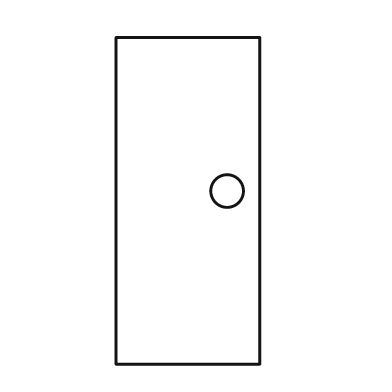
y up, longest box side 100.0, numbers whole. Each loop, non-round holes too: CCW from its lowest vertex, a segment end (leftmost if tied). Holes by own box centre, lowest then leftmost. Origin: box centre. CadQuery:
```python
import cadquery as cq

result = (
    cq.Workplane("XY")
    .moveTo(-22.0, -50.0)
    .lineTo(22.0, -50.0)
    .lineTo(22.0, 50.0)
    .lineTo(-22.0, 50.0)
    .close()
    .moveTo(12.0, 3.0)
    .circle(5.0)
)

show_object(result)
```